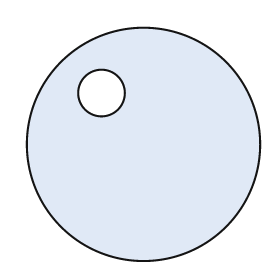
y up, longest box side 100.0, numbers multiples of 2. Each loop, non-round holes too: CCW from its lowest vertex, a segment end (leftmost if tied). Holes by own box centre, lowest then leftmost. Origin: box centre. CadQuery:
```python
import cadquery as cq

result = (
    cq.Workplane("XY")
    .moveTo(0.0, 0.0)
    .circle(50.0)
    .moveTo(-18.0, 22.0)
    .circle(10.0)
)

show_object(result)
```